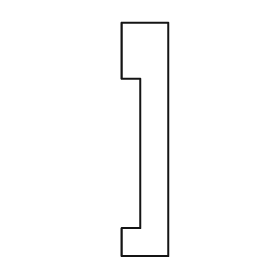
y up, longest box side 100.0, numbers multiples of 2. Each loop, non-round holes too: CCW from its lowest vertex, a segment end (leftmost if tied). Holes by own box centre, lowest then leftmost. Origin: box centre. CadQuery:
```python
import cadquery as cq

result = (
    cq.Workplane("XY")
    .moveTo(-10.0, -50.0)
    .lineTo(10.0, -50.0)
    .lineTo(10.0, 50.0)
    .lineTo(-10.0, 50.0)
    .lineTo(-10.0, 26.0)
    .lineTo(-2.0, 26.0)
    .lineTo(-2.0, -38.0)
    .lineTo(-10.0, -38.0)
    .close()
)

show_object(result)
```